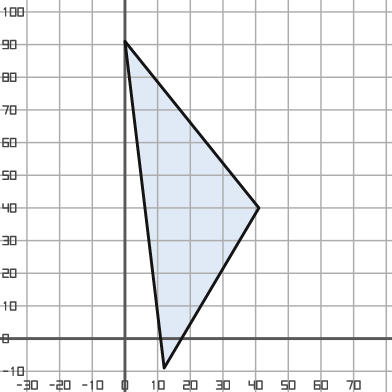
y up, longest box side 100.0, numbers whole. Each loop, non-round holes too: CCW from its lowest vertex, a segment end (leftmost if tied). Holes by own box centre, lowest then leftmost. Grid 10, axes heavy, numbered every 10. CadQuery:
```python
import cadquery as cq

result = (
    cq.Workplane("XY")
    .moveTo(12.0, -9.0)
    .lineTo(41.0, 40.0)
    .lineTo(0.0, 91.0)
    .close()
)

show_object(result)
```